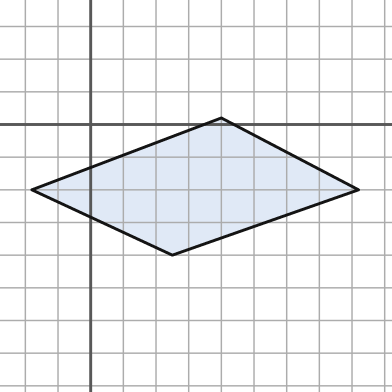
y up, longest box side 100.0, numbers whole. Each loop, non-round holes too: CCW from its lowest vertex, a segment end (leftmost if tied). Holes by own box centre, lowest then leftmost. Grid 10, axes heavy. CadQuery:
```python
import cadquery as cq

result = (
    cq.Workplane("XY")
    .moveTo(25.0, -40.0)
    .lineTo(82.0, -20.0)
    .lineTo(40.0, 2.0)
    .lineTo(-18.0, -20.0)
    .close()
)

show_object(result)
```